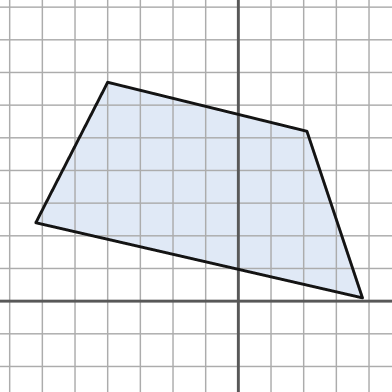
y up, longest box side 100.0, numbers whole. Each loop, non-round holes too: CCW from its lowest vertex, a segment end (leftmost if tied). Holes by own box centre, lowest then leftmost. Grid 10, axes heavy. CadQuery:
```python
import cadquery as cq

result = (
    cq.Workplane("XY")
    .moveTo(38.0, 1.0)
    .lineTo(21.0, 52.0)
    .lineTo(-40.0, 67.0)
    .lineTo(-62.0, 24.0)
    .close()
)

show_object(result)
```